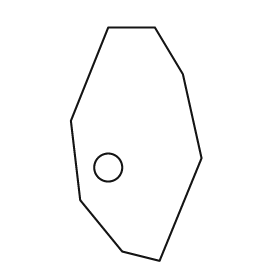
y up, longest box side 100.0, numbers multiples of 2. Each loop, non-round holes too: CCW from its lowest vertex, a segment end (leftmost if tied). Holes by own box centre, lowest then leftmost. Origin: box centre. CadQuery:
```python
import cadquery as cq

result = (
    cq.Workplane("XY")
    .moveTo(10.0, -50.0)
    .lineTo(28.0, -6.0)
    .lineTo(20.0, 30.0)
    .lineTo(8.0, 50.0)
    .lineTo(-12.0, 50.0)
    .lineTo(-28.0, 10.0)
    .lineTo(-24.0, -24.0)
    .lineTo(-6.0, -46.0)
    .close()
    .moveTo(-12.0, -10.0)
    .circle(6.0)
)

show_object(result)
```